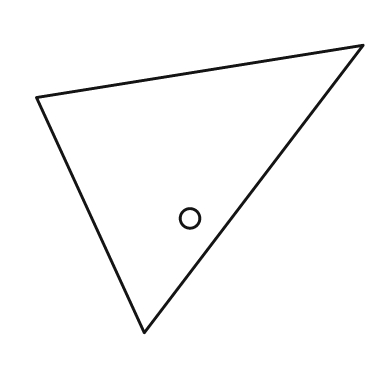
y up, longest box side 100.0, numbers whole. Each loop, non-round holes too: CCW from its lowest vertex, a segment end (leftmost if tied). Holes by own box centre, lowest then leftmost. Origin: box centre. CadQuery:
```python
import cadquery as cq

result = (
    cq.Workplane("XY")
    .moveTo(-17.0, -44.0)
    .lineTo(50.0, 44.0)
    .lineTo(-50.0, 28.0)
    .close()
    .moveTo(-3.0, -9.0)
    .circle(3.0)
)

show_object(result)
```